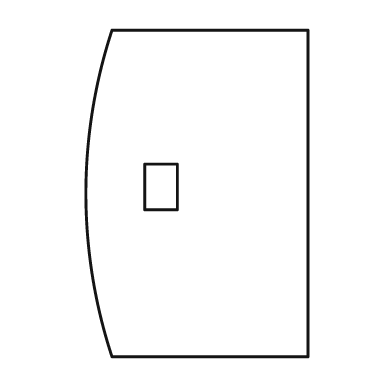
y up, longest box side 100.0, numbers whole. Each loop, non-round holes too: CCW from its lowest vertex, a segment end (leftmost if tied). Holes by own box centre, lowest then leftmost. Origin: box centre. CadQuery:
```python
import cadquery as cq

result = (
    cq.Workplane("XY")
    .moveTo(-26.0, -50.0)
    .lineTo(34.0, -50.0)
    .lineTo(34.0, 50.0)
    .lineTo(-26.0, 50.0)
    .threePointArc((-34.0, 0.0), (-26.0, -50.0))
    .close()
    .moveTo(-16.0, -5.0)
    .lineTo(-6.0, -5.0)
    .lineTo(-6.0, 9.0)
    .lineTo(-16.0, 9.0)
    .close()
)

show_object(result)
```